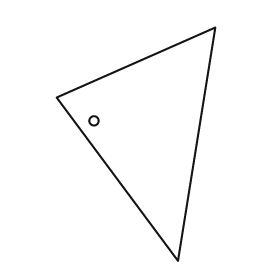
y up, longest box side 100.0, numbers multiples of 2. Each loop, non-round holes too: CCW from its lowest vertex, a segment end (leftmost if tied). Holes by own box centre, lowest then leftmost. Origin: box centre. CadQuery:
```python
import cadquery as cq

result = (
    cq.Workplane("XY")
    .moveTo(18.0, -50.0)
    .lineTo(34.0, 50.0)
    .lineTo(-34.0, 20.0)
    .close()
    .moveTo(-18.0, 10.0)
    .circle(2.0)
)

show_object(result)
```